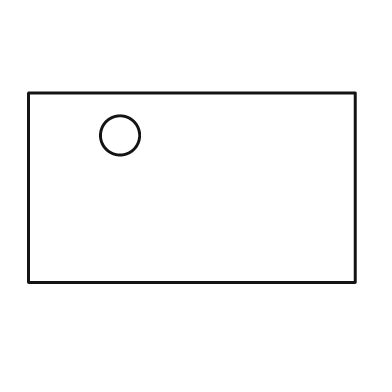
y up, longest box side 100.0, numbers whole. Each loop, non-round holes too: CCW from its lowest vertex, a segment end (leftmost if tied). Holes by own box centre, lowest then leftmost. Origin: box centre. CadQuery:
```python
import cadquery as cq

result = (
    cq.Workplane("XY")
    .moveTo(-50.0, -29.0)
    .lineTo(50.0, -29.0)
    .lineTo(50.0, 29.0)
    .lineTo(-50.0, 29.0)
    .close()
    .moveTo(-22.0, 16.0)
    .circle(6.0)
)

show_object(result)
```